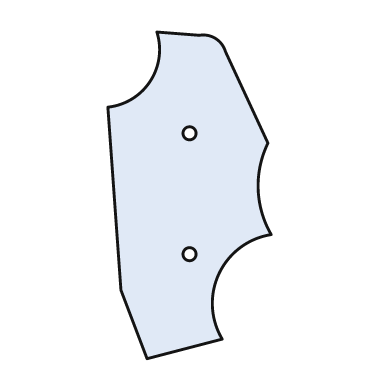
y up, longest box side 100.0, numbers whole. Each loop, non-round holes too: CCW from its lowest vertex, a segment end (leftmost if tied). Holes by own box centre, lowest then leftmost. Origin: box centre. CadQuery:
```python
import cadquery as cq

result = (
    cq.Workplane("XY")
    .moveTo(-13.0, -50.0)
    .lineTo(10.0, -44.0)
    .threePointArc((9.0, -24.0), (25.0, -12.0))
    .threePointArc((21.0, 2.0), (24.0, 16.0))
    .lineTo(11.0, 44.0)
    .threePointArc((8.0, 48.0), (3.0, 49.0))
    .lineTo(-10.0, 50.0)
    .threePointArc((-12.0, 35.0), (-25.0, 27.0))
    .lineTo(-21.0, -29.0)
    .close()
    .moveTo(0.0, -18.0)
    .circle(2.0)
    .moveTo(0.0, 19.0)
    .circle(2.0)
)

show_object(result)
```